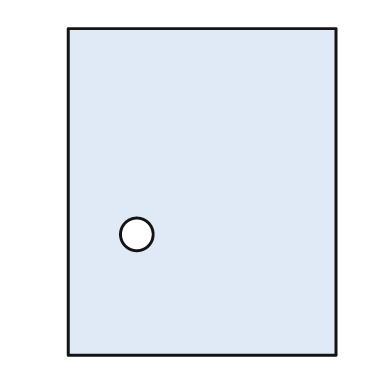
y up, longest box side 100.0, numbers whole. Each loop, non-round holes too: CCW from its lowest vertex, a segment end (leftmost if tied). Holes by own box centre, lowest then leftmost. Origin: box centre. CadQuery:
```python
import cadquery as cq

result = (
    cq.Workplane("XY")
    .moveTo(-41.0, -50.0)
    .lineTo(41.0, -50.0)
    .lineTo(41.0, 50.0)
    .lineTo(-41.0, 50.0)
    .close()
    .moveTo(-20.0, -13.0)
    .circle(5.0)
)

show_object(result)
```